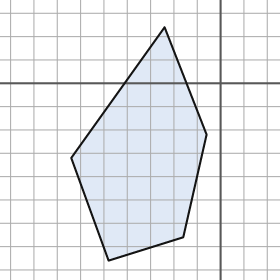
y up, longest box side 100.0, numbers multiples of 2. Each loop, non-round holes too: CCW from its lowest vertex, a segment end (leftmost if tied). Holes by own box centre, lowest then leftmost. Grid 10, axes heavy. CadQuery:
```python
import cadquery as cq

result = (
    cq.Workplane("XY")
    .moveTo(-48.0, -76.0)
    .lineTo(-16.0, -66.0)
    .lineTo(-6.0, -22.0)
    .lineTo(-24.0, 24.0)
    .lineTo(-64.0, -32.0)
    .close()
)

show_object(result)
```